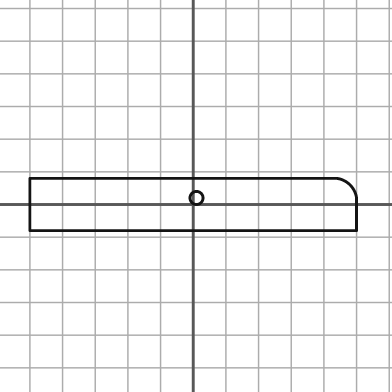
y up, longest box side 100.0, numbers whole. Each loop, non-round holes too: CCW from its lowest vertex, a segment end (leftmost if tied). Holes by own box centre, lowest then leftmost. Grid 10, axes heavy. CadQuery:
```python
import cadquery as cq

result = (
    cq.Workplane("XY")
    .moveTo(-50.0, -8.0)
    .lineTo(50.0, -8.0)
    .lineTo(50.0, 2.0)
    .threePointArc((48.0, 6.0), (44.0, 8.0))
    .lineTo(-50.0, 8.0)
    .close()
    .moveTo(1.0, 2.0)
    .circle(2.0)
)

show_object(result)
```